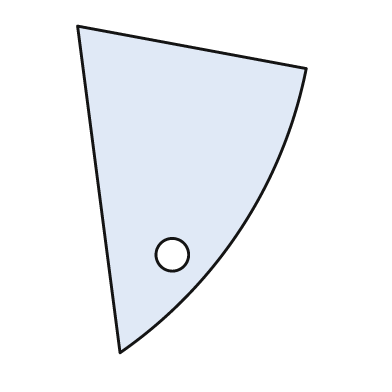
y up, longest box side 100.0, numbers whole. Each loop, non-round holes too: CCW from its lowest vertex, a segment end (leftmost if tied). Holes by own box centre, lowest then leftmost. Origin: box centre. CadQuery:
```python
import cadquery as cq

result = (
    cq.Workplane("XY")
    .moveTo(-22.0, -50.0)
    .threePointArc((15.0, -12.0), (35.0, 37.0))
    .lineTo(-35.0, 50.0)
    .close()
    .moveTo(-6.0, -20.0)
    .circle(5.0)
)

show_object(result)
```